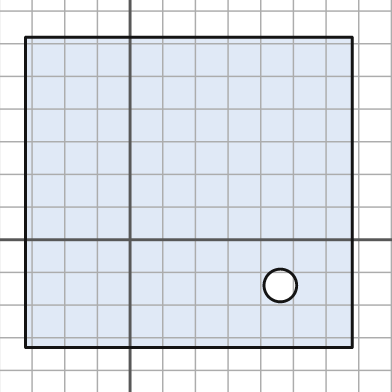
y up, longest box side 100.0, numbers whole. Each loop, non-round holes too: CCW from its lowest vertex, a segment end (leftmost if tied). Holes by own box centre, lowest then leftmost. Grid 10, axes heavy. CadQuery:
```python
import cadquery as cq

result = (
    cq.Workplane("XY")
    .moveTo(-32.0, -33.0)
    .lineTo(68.0, -33.0)
    .lineTo(68.0, 62.0)
    .lineTo(-32.0, 62.0)
    .close()
    .moveTo(46.0, -14.0)
    .circle(5.0)
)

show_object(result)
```